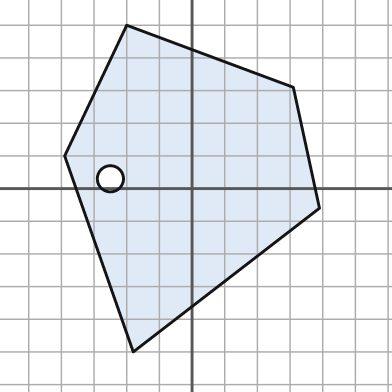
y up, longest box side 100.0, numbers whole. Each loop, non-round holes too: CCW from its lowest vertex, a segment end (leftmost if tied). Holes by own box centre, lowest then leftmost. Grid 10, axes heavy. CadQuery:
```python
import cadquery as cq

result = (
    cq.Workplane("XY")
    .moveTo(-18.0, -50.0)
    .lineTo(39.0, -6.0)
    .lineTo(31.0, 31.0)
    .lineTo(-20.0, 50.0)
    .lineTo(-39.0, 10.0)
    .close()
    .moveTo(-25.0, 3.0)
    .circle(4.0)
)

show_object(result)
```